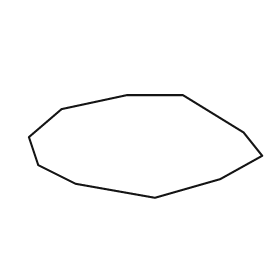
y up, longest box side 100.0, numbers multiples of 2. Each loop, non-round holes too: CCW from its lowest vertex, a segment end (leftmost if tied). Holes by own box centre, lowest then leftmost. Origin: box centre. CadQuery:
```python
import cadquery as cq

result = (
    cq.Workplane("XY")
    .moveTo(4.0, -22.0)
    .lineTo(32.0, -14.0)
    .lineTo(50.0, -4.0)
    .lineTo(42.0, 6.0)
    .lineTo(16.0, 22.0)
    .lineTo(-8.0, 22.0)
    .lineTo(-36.0, 16.0)
    .lineTo(-50.0, 4.0)
    .lineTo(-46.0, -8.0)
    .lineTo(-30.0, -16.0)
    .close()
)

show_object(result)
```